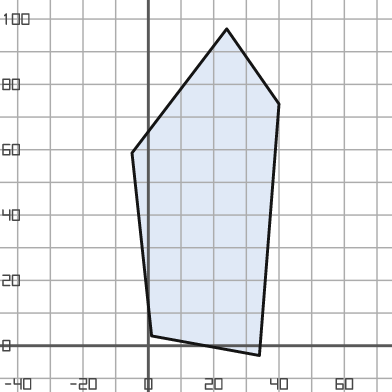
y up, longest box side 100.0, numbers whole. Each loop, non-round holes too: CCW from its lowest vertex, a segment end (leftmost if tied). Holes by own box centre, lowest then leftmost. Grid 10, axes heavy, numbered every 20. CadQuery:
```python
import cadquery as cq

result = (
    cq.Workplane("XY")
    .moveTo(34.0, -3.0)
    .lineTo(40.0, 74.0)
    .lineTo(24.0, 97.0)
    .lineTo(-5.0, 59.0)
    .lineTo(1.0, 3.0)
    .close()
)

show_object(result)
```